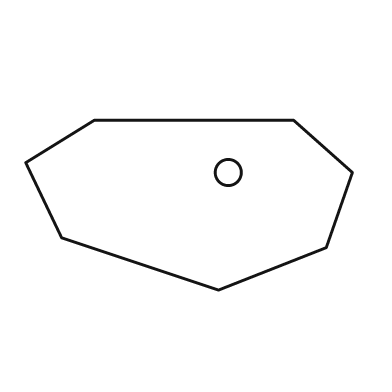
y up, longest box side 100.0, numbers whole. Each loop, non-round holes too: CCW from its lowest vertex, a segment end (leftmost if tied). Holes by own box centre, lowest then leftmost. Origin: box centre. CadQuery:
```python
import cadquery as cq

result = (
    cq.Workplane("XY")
    .moveTo(9.0, -26.0)
    .lineTo(42.0, -13.0)
    .lineTo(50.0, 10.0)
    .lineTo(32.0, 26.0)
    .lineTo(-29.0, 26.0)
    .lineTo(-50.0, 13.0)
    .lineTo(-39.0, -10.0)
    .close()
    .moveTo(12.0, 10.0)
    .circle(4.0)
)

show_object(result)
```